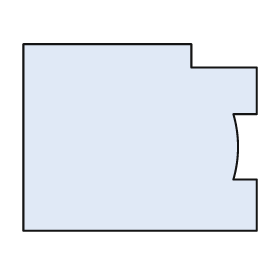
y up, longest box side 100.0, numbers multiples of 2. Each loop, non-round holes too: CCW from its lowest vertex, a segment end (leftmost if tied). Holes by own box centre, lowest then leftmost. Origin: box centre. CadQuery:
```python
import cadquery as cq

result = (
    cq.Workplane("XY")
    .moveTo(-50.0, -40.0)
    .lineTo(50.0, -40.0)
    .lineTo(50.0, -18.0)
    .lineTo(40.0, -18.0)
    .threePointArc((42.0, -4.0), (40.0, 10.0))
    .lineTo(50.0, 10.0)
    .lineTo(50.0, 30.0)
    .lineTo(22.0, 30.0)
    .lineTo(22.0, 40.0)
    .lineTo(-50.0, 40.0)
    .close()
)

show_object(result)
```